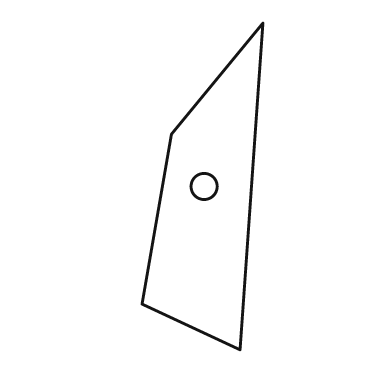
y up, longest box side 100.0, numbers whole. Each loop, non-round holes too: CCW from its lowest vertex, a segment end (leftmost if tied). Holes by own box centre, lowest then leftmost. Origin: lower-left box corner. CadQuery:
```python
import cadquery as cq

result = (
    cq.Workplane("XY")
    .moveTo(30.0, 0.0)
    .lineTo(37.0, 100.0)
    .lineTo(9.0, 66.0)
    .lineTo(0.0, 14.0)
    .close()
    .moveTo(19.0, 50.0)
    .circle(4.0)
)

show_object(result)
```